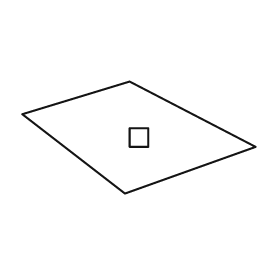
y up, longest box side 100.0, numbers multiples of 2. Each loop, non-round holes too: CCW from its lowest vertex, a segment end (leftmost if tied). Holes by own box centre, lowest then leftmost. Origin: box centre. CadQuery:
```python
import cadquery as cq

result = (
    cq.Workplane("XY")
    .moveTo(-6.0, -24.0)
    .lineTo(50.0, -4.0)
    .lineTo(-4.0, 24.0)
    .lineTo(-50.0, 10.0)
    .close()
    .moveTo(-4.0, -4.0)
    .lineTo(4.0, -4.0)
    .lineTo(4.0, 4.0)
    .lineTo(-4.0, 4.0)
    .close()
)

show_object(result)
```